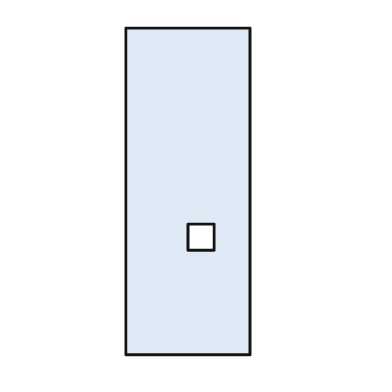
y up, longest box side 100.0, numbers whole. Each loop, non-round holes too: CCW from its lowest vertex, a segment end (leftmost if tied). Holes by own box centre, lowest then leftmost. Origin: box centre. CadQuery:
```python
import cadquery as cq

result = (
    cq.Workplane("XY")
    .moveTo(-19.0, -50.0)
    .lineTo(19.0, -50.0)
    .lineTo(19.0, 50.0)
    .lineTo(-19.0, 50.0)
    .close()
    .moveTo(0.0, -18.0)
    .lineTo(8.0, -18.0)
    .lineTo(8.0, -10.0)
    .lineTo(0.0, -10.0)
    .close()
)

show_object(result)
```